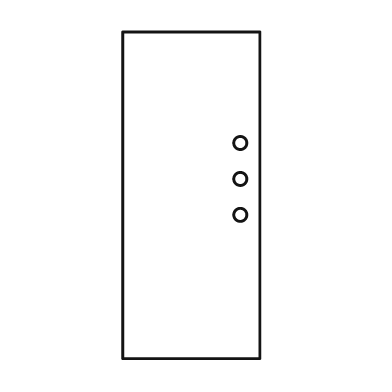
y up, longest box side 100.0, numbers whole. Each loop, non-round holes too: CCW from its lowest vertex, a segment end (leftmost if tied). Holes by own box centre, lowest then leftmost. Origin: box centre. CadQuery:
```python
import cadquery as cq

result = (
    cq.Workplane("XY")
    .moveTo(-21.0, -50.0)
    .lineTo(21.0, -50.0)
    .lineTo(21.0, 50.0)
    .lineTo(-21.0, 50.0)
    .close()
    .moveTo(15.0, -6.0)
    .circle(2.0)
    .moveTo(15.0, 5.0)
    .circle(2.0)
    .moveTo(15.0, 16.0)
    .circle(2.0)
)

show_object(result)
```